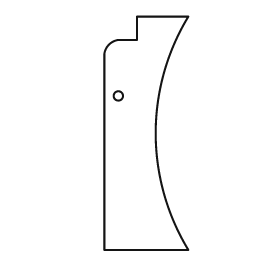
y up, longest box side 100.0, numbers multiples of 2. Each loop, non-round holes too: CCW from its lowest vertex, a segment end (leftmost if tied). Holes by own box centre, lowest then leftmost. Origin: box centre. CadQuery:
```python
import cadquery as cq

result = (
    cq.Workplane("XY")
    .moveTo(-18.0, -50.0)
    .lineTo(18.0, -50.0)
    .threePointArc((4.0, 0.0), (18.0, 50.0))
    .lineTo(-4.0, 50.0)
    .lineTo(-4.0, 40.0)
    .lineTo(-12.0, 40.0)
    .threePointArc((-16.0, 38.0), (-18.0, 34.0))
    .close()
    .moveTo(-12.0, 16.0)
    .circle(2.0)
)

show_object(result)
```